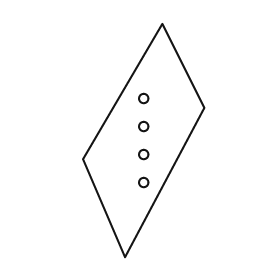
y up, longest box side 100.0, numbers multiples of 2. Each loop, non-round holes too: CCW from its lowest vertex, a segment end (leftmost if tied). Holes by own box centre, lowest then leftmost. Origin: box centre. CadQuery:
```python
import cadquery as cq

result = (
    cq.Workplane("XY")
    .moveTo(-8.0, -50.0)
    .lineTo(26.0, 14.0)
    .lineTo(8.0, 50.0)
    .lineTo(-26.0, -8.0)
    .close()
    .moveTo(0.0, -18.0)
    .circle(2.0)
    .moveTo(0.0, -6.0)
    .circle(2.0)
    .moveTo(0.0, 6.0)
    .circle(2.0)
    .moveTo(0.0, 18.0)
    .circle(2.0)
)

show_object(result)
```